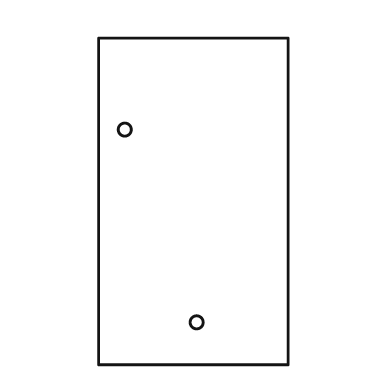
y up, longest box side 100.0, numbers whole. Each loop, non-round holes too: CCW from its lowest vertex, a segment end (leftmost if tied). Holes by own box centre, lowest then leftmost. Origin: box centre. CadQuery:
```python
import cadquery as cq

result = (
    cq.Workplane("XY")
    .moveTo(-29.0, -50.0)
    .lineTo(29.0, -50.0)
    .lineTo(29.0, 50.0)
    .lineTo(-29.0, 50.0)
    .close()
    .moveTo(1.0, -37.0)
    .circle(2.0)
    .moveTo(-21.0, 22.0)
    .circle(2.0)
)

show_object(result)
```